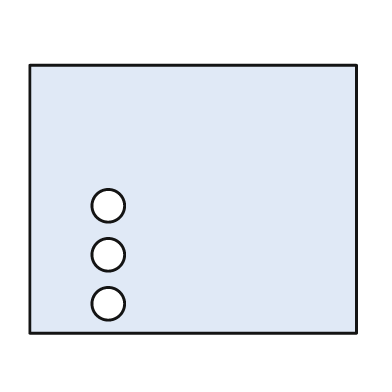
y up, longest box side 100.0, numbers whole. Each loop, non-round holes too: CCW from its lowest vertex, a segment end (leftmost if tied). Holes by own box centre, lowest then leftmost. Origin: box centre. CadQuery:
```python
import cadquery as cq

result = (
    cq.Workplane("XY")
    .moveTo(-50.0, -41.0)
    .lineTo(50.0, -41.0)
    .lineTo(50.0, 41.0)
    .lineTo(-50.0, 41.0)
    .close()
    .moveTo(-26.0, -32.0)
    .circle(5.0)
    .moveTo(-26.0, -17.0)
    .circle(5.0)
    .moveTo(-26.0, -2.0)
    .circle(5.0)
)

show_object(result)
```